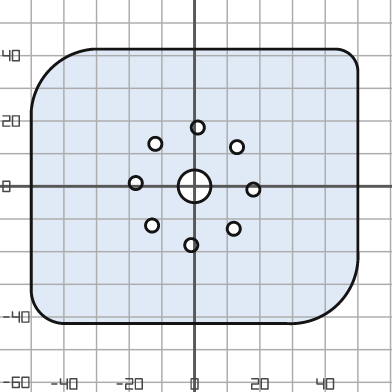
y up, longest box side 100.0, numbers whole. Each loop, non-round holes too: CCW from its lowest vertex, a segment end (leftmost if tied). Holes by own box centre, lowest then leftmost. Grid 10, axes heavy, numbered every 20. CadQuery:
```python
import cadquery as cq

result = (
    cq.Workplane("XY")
    .moveTo(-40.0, -42.0)
    .lineTo(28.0, -42.0)
    .threePointArc((44.0, -36.0), (50.0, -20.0))
    .lineTo(50.0, 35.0)
    .threePointArc((48.0, 40.0), (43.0, 42.0))
    .lineTo(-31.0, 42.0)
    .threePointArc((-44.0, 36.0), (-50.0, 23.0))
    .lineTo(-50.0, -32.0)
    .threePointArc((-47.0, -39.0), (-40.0, -42.0))
    .close()
    .moveTo(-1.0, -18.0)
    .circle(2.0)
    .moveTo(12.0, -13.0)
    .circle(2.0)
    .moveTo(-13.0, -12.0)
    .circle(2.0)
    .moveTo(18.0, -1.0)
    .circle(2.0)
    .moveTo(0.0, 0.0)
    .circle(5.0)
    .moveTo(-18.0, 1.0)
    .circle(2.0)
    .moveTo(13.0, 12.0)
    .circle(2.0)
    .moveTo(-12.0, 13.0)
    .circle(2.0)
    .moveTo(1.0, 18.0)
    .circle(2.0)
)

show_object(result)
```